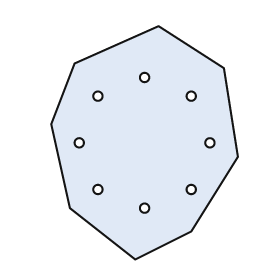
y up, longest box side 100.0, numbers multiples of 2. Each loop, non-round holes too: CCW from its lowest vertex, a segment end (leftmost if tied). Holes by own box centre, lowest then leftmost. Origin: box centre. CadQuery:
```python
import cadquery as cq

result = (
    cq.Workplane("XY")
    .moveTo(-4.0, -50.0)
    .lineTo(20.0, -38.0)
    .lineTo(40.0, -6.0)
    .lineTo(34.0, 32.0)
    .lineTo(6.0, 50.0)
    .lineTo(-30.0, 34.0)
    .lineTo(-40.0, 8.0)
    .lineTo(-32.0, -28.0)
    .close()
    .moveTo(0.0, -28.0)
    .circle(2.0)
    .moveTo(-20.0, -20.0)
    .circle(2.0)
    .moveTo(20.0, -20.0)
    .circle(2.0)
    .moveTo(-28.0, 0.0)
    .circle(2.0)
    .moveTo(28.0, 0.0)
    .circle(2.0)
    .moveTo(-20.0, 20.0)
    .circle(2.0)
    .moveTo(20.0, 20.0)
    .circle(2.0)
    .moveTo(0.0, 28.0)
    .circle(2.0)
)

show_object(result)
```